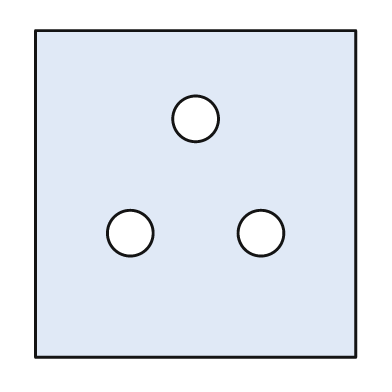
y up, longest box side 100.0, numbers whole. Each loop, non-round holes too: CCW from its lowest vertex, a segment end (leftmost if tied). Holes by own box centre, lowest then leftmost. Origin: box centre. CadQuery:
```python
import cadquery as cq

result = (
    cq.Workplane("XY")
    .moveTo(-49.0, -50.0)
    .lineTo(49.0, -50.0)
    .lineTo(49.0, 50.0)
    .lineTo(-49.0, 50.0)
    .close()
    .moveTo(-20.0, -12.0)
    .circle(7.0)
    .moveTo(20.0, -12.0)
    .circle(7.0)
    .moveTo(0.0, 23.0)
    .circle(7.0)
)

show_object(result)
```